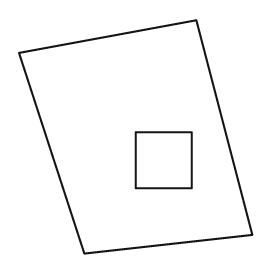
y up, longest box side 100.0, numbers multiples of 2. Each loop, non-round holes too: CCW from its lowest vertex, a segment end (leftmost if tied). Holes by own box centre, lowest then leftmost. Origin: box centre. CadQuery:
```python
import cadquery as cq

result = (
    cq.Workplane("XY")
    .moveTo(-22.0, -50.0)
    .lineTo(50.0, -42.0)
    .lineTo(26.0, 50.0)
    .lineTo(-50.0, 36.0)
    .close()
    .moveTo(0.0, -22.0)
    .lineTo(24.0, -22.0)
    .lineTo(24.0, 2.0)
    .lineTo(0.0, 2.0)
    .close()
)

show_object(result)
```